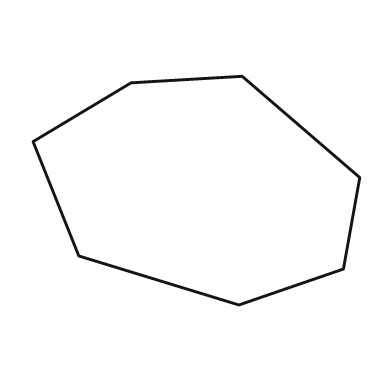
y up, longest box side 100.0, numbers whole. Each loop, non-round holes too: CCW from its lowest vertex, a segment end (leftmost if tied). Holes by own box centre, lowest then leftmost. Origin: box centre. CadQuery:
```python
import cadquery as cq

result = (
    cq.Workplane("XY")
    .moveTo(13.0, -35.0)
    .lineTo(45.0, -24.0)
    .lineTo(50.0, 4.0)
    .lineTo(14.0, 35.0)
    .lineTo(-20.0, 33.0)
    .lineTo(-50.0, 15.0)
    .lineTo(-36.0, -20.0)
    .close()
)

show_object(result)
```